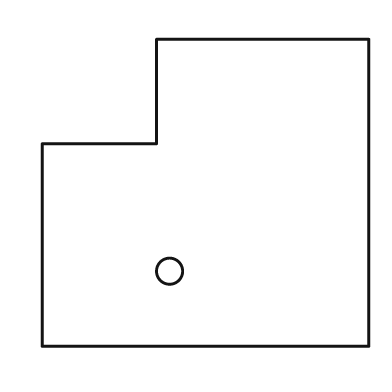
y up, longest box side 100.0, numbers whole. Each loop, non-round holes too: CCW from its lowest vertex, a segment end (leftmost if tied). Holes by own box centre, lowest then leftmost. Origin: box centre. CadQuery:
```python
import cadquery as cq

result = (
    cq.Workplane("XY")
    .moveTo(-50.0, -47.0)
    .lineTo(50.0, -47.0)
    .lineTo(50.0, 47.0)
    .lineTo(-15.0, 47.0)
    .lineTo(-15.0, 15.0)
    .lineTo(-50.0, 15.0)
    .close()
    .moveTo(-11.0, -24.0)
    .circle(4.0)
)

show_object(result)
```